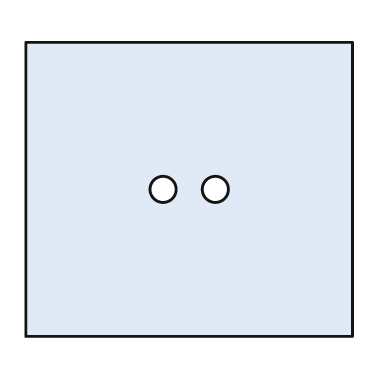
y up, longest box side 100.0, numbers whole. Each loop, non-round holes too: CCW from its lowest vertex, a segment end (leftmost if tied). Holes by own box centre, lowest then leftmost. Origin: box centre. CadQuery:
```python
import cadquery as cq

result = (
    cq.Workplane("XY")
    .moveTo(-50.0, -45.0)
    .lineTo(50.0, -45.0)
    .lineTo(50.0, 45.0)
    .lineTo(-50.0, 45.0)
    .close()
    .moveTo(-8.0, 0.0)
    .circle(4.0)
    .moveTo(8.0, 0.0)
    .circle(4.0)
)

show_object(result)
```